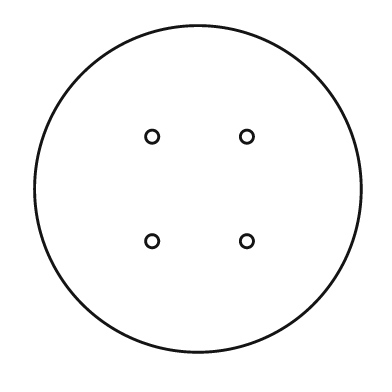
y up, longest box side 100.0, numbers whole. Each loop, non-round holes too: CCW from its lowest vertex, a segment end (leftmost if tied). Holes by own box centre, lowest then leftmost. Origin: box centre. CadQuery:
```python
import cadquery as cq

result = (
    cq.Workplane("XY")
    .moveTo(0.0, 0.0)
    .circle(50.0)
    .moveTo(-14.0, -16.0)
    .circle(2.0)
    .moveTo(15.0, -16.0)
    .circle(2.0)
    .moveTo(-14.0, 16.0)
    .circle(2.0)
    .moveTo(15.0, 16.0)
    .circle(2.0)
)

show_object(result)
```